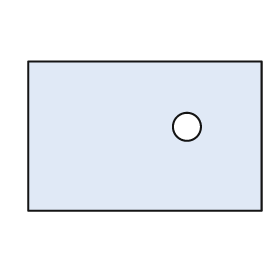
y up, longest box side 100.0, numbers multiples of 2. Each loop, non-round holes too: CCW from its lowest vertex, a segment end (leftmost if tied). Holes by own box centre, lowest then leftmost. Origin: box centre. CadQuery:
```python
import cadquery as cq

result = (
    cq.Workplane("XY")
    .moveTo(-50.0, -32.0)
    .lineTo(50.0, -32.0)
    .lineTo(50.0, 32.0)
    .lineTo(-50.0, 32.0)
    .close()
    .moveTo(18.0, 4.0)
    .circle(6.0)
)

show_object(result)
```